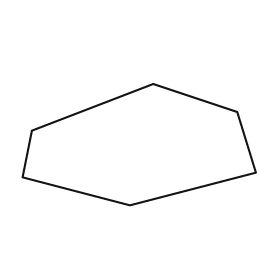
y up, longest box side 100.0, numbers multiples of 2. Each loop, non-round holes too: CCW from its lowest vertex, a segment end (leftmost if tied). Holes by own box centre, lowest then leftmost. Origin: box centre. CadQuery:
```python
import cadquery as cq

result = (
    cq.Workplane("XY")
    .moveTo(-4.0, -26.0)
    .lineTo(50.0, -12.0)
    .lineTo(42.0, 14.0)
    .lineTo(6.0, 26.0)
    .lineTo(-46.0, 6.0)
    .lineTo(-50.0, -14.0)
    .close()
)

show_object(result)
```